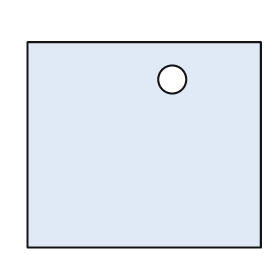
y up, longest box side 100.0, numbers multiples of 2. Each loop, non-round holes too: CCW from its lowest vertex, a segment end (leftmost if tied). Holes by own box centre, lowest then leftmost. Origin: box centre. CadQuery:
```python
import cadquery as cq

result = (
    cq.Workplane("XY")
    .moveTo(-50.0, -44.0)
    .lineTo(50.0, -44.0)
    .lineTo(50.0, 44.0)
    .lineTo(-50.0, 44.0)
    .close()
    .moveTo(12.0, 28.0)
    .circle(6.0)
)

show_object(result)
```